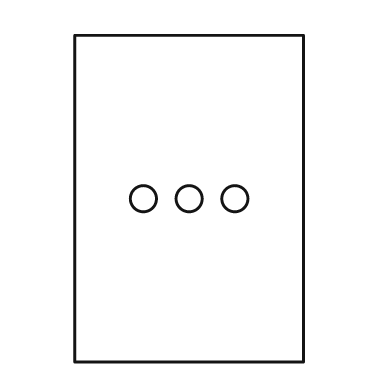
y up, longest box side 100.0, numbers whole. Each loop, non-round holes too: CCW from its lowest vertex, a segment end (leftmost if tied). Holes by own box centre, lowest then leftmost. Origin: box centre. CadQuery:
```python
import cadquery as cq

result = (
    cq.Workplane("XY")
    .moveTo(-35.0, -50.0)
    .lineTo(35.0, -50.0)
    .lineTo(35.0, 50.0)
    .lineTo(-35.0, 50.0)
    .close()
    .moveTo(-14.0, 0.0)
    .circle(4.0)
    .moveTo(0.0, 0.0)
    .circle(4.0)
    .moveTo(14.0, 0.0)
    .circle(4.0)
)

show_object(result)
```